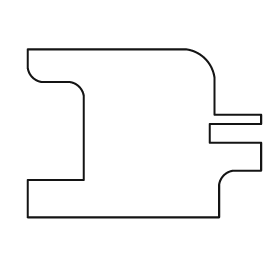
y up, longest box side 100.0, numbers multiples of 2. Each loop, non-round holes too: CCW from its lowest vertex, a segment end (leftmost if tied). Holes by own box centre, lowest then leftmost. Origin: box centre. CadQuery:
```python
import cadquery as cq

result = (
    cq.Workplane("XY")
    .moveTo(-50.0, -36.0)
    .lineTo(32.0, -36.0)
    .lineTo(32.0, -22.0)
    .threePointArc((34.0, -18.0), (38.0, -16.0))
    .lineTo(50.0, -16.0)
    .lineTo(50.0, -4.0)
    .lineTo(28.0, -4.0)
    .lineTo(28.0, 4.0)
    .lineTo(50.0, 4.0)
    .lineTo(50.0, 8.0)
    .lineTo(30.0, 8.0)
    .lineTo(30.0, 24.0)
    .threePointArc((26.0, 32.0), (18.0, 36.0))
    .lineTo(-50.0, 36.0)
    .lineTo(-50.0, 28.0)
    .threePointArc((-48.0, 24.0), (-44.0, 22.0))
    .lineTo(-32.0, 22.0)
    .threePointArc((-28.0, 20.0), (-26.0, 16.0))
    .lineTo(-26.0, -20.0)
    .lineTo(-50.0, -20.0)
    .close()
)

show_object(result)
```